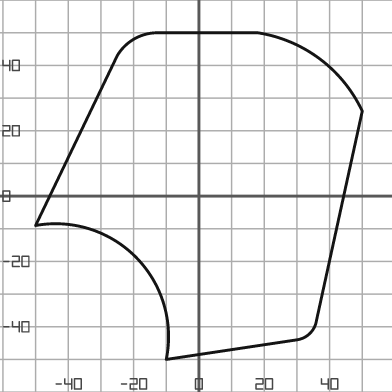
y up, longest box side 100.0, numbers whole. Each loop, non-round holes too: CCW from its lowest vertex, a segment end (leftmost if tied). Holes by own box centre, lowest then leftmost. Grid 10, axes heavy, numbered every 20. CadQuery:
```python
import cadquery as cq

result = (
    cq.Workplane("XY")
    .moveTo(-10.0, -50.0)
    .lineTo(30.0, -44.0)
    .threePointArc((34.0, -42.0), (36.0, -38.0))
    .lineTo(50.0, 26.0)
    .threePointArc((37.0, 42.0), (18.0, 50.0))
    .lineTo(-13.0, 50.0)
    .threePointArc((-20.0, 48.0), (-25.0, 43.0))
    .lineTo(-50.0, -9.0)
    .threePointArc((-19.0, -19.0), (-10.0, -50.0))
    .close()
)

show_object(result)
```